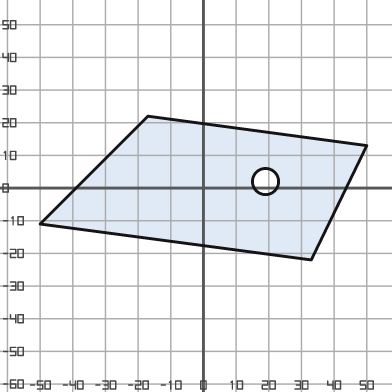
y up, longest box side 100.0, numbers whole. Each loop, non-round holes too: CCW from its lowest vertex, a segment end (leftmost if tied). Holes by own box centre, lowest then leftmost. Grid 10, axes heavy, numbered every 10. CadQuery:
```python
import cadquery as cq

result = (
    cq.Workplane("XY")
    .moveTo(33.0, -22.0)
    .lineTo(50.0, 13.0)
    .lineTo(-17.0, 22.0)
    .lineTo(-50.0, -11.0)
    .close()
    .moveTo(19.0, 2.0)
    .circle(4.0)
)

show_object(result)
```